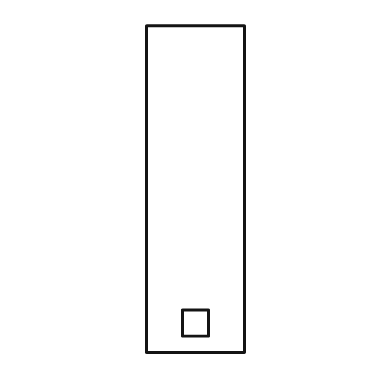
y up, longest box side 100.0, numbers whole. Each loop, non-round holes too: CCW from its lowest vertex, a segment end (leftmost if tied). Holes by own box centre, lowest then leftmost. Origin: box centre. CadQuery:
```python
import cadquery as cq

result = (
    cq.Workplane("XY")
    .moveTo(-15.0, -50.0)
    .lineTo(15.0, -50.0)
    .lineTo(15.0, 50.0)
    .lineTo(-15.0, 50.0)
    .close()
    .moveTo(-4.0, -45.0)
    .lineTo(4.0, -45.0)
    .lineTo(4.0, -37.0)
    .lineTo(-4.0, -37.0)
    .close()
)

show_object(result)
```